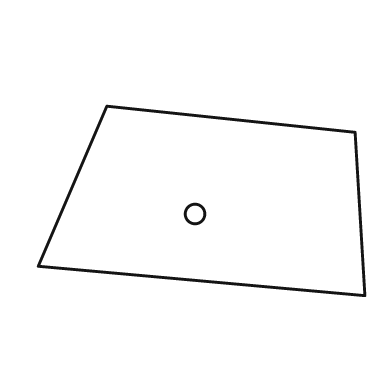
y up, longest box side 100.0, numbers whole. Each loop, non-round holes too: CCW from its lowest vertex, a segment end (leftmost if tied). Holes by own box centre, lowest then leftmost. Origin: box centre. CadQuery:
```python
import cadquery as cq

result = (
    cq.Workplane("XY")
    .moveTo(50.0, -29.0)
    .lineTo(47.0, 21.0)
    .lineTo(-29.0, 29.0)
    .lineTo(-50.0, -20.0)
    .close()
    .moveTo(-2.0, -4.0)
    .circle(3.0)
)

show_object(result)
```